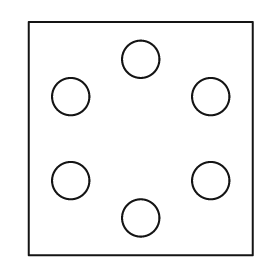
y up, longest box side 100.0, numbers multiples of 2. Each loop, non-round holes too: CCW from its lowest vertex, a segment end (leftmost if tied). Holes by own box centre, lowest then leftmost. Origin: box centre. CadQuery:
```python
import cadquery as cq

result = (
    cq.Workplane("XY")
    .moveTo(-48.0, -50.0)
    .lineTo(48.0, -50.0)
    .lineTo(48.0, 50.0)
    .lineTo(-48.0, 50.0)
    .close()
    .moveTo(0.0, -34.0)
    .circle(8.0)
    .moveTo(-30.0, -18.0)
    .circle(8.0)
    .moveTo(30.0, -18.0)
    .circle(8.0)
    .moveTo(-30.0, 18.0)
    .circle(8.0)
    .moveTo(30.0, 18.0)
    .circle(8.0)
    .moveTo(0.0, 34.0)
    .circle(8.0)
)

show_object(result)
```